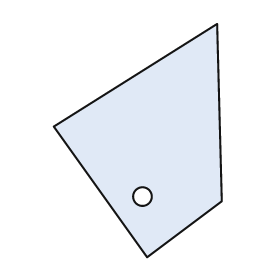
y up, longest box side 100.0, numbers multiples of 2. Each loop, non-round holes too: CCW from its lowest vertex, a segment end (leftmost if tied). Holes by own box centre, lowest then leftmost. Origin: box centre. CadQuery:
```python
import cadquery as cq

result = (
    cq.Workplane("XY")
    .moveTo(4.0, -50.0)
    .lineTo(36.0, -26.0)
    .lineTo(34.0, 50.0)
    .lineTo(-36.0, 6.0)
    .close()
    .moveTo(2.0, -24.0)
    .circle(4.0)
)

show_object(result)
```